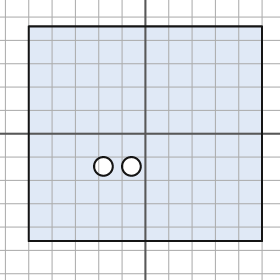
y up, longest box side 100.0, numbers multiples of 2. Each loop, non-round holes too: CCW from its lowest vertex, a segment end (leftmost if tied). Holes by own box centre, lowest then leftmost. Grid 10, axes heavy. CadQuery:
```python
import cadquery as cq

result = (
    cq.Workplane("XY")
    .moveTo(-50.0, -46.0)
    .lineTo(50.0, -46.0)
    .lineTo(50.0, 46.0)
    .lineTo(-50.0, 46.0)
    .close()
    .moveTo(-18.0, -14.0)
    .circle(4.0)
    .moveTo(-6.0, -14.0)
    .circle(4.0)
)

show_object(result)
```